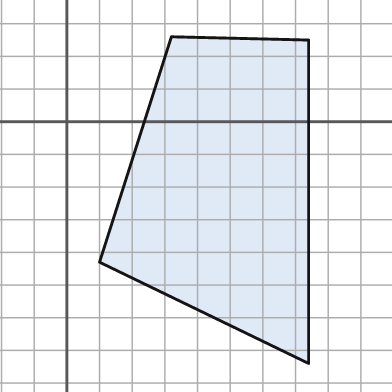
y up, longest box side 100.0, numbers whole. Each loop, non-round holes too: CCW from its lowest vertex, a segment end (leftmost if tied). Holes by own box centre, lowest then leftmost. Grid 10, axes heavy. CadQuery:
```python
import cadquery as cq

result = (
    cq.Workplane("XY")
    .moveTo(74.0, -74.0)
    .lineTo(74.0, 25.0)
    .lineTo(32.0, 26.0)
    .lineTo(10.0, -43.0)
    .close()
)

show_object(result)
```